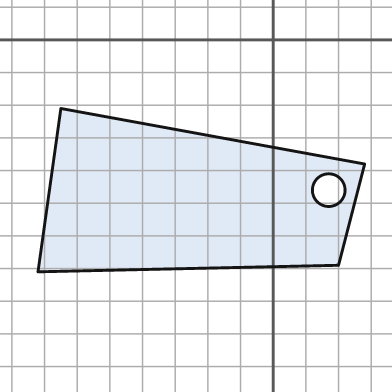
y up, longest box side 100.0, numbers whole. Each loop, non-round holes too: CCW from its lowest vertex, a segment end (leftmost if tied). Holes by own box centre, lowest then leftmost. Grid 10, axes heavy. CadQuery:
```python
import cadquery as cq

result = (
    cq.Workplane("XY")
    .moveTo(-72.0, -71.0)
    .lineTo(20.0, -69.0)
    .lineTo(28.0, -38.0)
    .lineTo(-65.0, -21.0)
    .close()
    .moveTo(17.0, -46.0)
    .circle(5.0)
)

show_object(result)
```